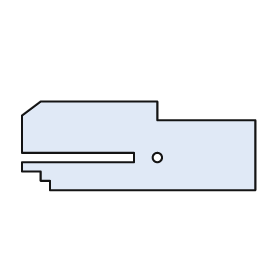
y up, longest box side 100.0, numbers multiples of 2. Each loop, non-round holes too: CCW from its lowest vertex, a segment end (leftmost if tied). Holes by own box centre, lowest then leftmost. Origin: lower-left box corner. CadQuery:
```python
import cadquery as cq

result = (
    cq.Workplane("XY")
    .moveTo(12.0, 0.0)
    .lineTo(100.0, 0.0)
    .lineTo(100.0, 30.0)
    .lineTo(58.0, 30.0)
    .lineTo(58.0, 38.0)
    .lineTo(8.0, 38.0)
    .lineTo(0.0, 32.0)
    .lineTo(0.0, 16.0)
    .lineTo(48.0, 16.0)
    .lineTo(48.0, 12.0)
    .lineTo(0.0, 12.0)
    .lineTo(0.0, 8.0)
    .lineTo(8.0, 8.0)
    .lineTo(8.0, 4.0)
    .lineTo(12.0, 4.0)
    .close()
    .moveTo(58.0, 14.0)
    .circle(2.0)
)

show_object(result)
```